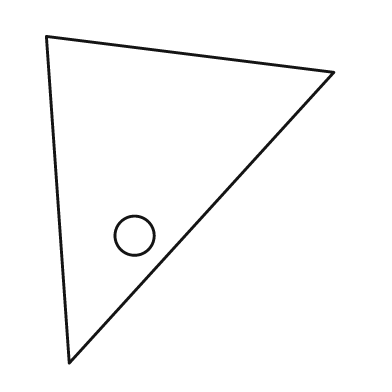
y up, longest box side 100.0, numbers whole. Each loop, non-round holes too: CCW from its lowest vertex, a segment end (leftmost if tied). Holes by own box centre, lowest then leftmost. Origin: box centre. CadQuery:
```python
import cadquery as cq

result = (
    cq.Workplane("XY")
    .moveTo(-37.0, -50.0)
    .lineTo(44.0, 39.0)
    .lineTo(-44.0, 50.0)
    .close()
    .moveTo(-17.0, -11.0)
    .circle(6.0)
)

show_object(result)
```